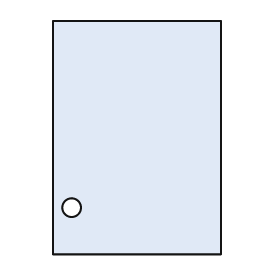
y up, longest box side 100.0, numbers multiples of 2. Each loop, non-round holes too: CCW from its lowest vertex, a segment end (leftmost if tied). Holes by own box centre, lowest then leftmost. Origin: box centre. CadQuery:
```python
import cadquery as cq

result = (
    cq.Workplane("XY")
    .moveTo(-36.0, -50.0)
    .lineTo(36.0, -50.0)
    .lineTo(36.0, 50.0)
    .lineTo(-36.0, 50.0)
    .close()
    .moveTo(-28.0, -30.0)
    .circle(4.0)
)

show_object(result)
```